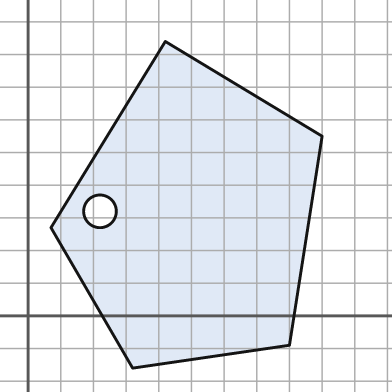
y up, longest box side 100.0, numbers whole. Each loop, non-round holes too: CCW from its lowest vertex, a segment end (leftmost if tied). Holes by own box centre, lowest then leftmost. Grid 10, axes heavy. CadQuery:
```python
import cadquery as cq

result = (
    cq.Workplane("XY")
    .moveTo(32.0, -16.0)
    .lineTo(80.0, -9.0)
    .lineTo(90.0, 55.0)
    .lineTo(42.0, 84.0)
    .lineTo(7.0, 27.0)
    .close()
    .moveTo(22.0, 32.0)
    .circle(5.0)
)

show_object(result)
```